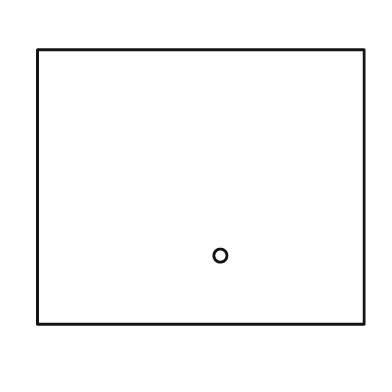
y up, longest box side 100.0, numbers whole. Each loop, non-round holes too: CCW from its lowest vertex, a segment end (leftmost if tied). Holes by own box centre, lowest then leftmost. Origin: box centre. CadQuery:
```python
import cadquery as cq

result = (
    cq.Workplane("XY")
    .moveTo(-50.0, -42.0)
    .lineTo(50.0, -42.0)
    .lineTo(50.0, 42.0)
    .lineTo(-50.0, 42.0)
    .close()
    .moveTo(6.0, -21.0)
    .circle(2.0)
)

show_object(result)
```